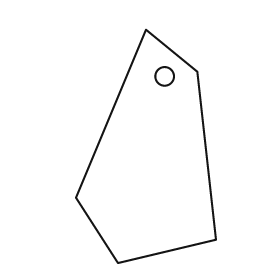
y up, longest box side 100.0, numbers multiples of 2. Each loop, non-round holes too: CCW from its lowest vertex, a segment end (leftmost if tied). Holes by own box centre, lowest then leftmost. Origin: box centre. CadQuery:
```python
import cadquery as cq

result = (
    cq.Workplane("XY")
    .moveTo(-12.0, -50.0)
    .lineTo(30.0, -40.0)
    .lineTo(22.0, 32.0)
    .lineTo(0.0, 50.0)
    .lineTo(-30.0, -22.0)
    .close()
    .moveTo(8.0, 30.0)
    .circle(4.0)
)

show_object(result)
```